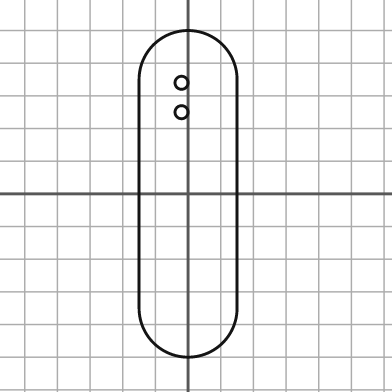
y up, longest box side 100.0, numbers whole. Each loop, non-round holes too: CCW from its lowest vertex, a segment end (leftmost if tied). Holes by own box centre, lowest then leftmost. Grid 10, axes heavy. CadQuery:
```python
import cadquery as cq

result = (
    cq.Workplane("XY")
    .moveTo(-15.0, -35.0)
    .threePointArc((0.0, -50.0), (15.0, -35.0))
    .lineTo(15.0, 35.0)
    .threePointArc((0.0, 50.0), (-15.0, 35.0))
    .close()
    .moveTo(-2.0, 25.0)
    .circle(2.0)
    .moveTo(-2.0, 34.0)
    .circle(2.0)
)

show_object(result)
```